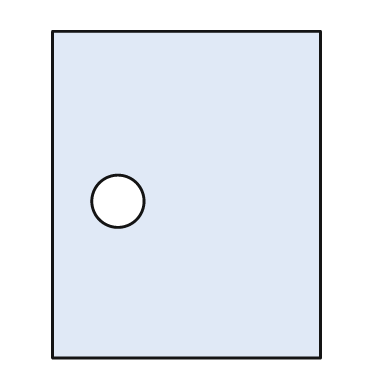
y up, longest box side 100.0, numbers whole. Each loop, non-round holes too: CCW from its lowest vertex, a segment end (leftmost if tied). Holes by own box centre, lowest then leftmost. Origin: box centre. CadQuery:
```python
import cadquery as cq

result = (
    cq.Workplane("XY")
    .moveTo(-41.0, -50.0)
    .lineTo(41.0, -50.0)
    .lineTo(41.0, 50.0)
    .lineTo(-41.0, 50.0)
    .close()
    .moveTo(-21.0, -2.0)
    .circle(8.0)
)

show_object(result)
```